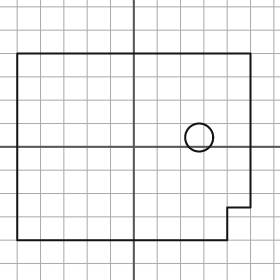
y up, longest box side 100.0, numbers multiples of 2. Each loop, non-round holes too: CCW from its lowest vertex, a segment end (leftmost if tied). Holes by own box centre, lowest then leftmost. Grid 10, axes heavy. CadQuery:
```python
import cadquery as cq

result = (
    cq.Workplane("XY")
    .moveTo(-50.0, -40.0)
    .lineTo(40.0, -40.0)
    .lineTo(40.0, -26.0)
    .lineTo(50.0, -26.0)
    .lineTo(50.0, 40.0)
    .lineTo(-50.0, 40.0)
    .close()
    .moveTo(28.0, 4.0)
    .circle(6.0)
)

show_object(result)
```